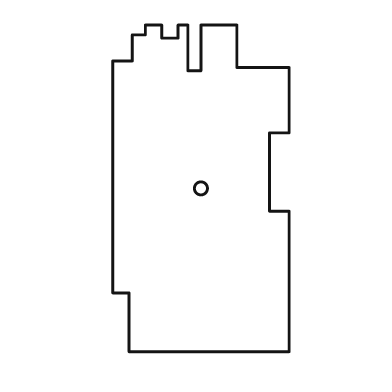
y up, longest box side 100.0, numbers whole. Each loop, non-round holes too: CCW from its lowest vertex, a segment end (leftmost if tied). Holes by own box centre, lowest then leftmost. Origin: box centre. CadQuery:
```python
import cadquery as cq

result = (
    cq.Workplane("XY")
    .moveTo(-22.0, -50.0)
    .lineTo(27.0, -50.0)
    .lineTo(27.0, -7.0)
    .lineTo(21.0, -7.0)
    .lineTo(21.0, 17.0)
    .lineTo(27.0, 17.0)
    .lineTo(27.0, 37.0)
    .lineTo(11.0, 37.0)
    .lineTo(11.0, 50.0)
    .lineTo(0.0, 50.0)
    .lineTo(0.0, 36.0)
    .lineTo(-4.0, 36.0)
    .lineTo(-4.0, 50.0)
    .lineTo(-7.0, 50.0)
    .lineTo(-7.0, 46.0)
    .lineTo(-12.0, 46.0)
    .lineTo(-12.0, 50.0)
    .lineTo(-17.0, 50.0)
    .lineTo(-17.0, 47.0)
    .lineTo(-21.0, 47.0)
    .lineTo(-21.0, 39.0)
    .lineTo(-27.0, 39.0)
    .lineTo(-27.0, -32.0)
    .lineTo(-22.0, -32.0)
    .close()
    .moveTo(0.0, 0.0)
    .circle(2.0)
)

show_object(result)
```